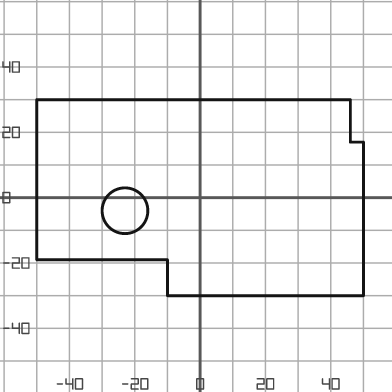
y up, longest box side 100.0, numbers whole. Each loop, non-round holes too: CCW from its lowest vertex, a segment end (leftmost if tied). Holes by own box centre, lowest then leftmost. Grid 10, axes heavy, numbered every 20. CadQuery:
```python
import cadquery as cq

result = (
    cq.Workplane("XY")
    .moveTo(-10.0, -30.0)
    .lineTo(50.0, -30.0)
    .lineTo(50.0, 17.0)
    .lineTo(46.0, 17.0)
    .lineTo(46.0, 30.0)
    .lineTo(-50.0, 30.0)
    .lineTo(-50.0, -19.0)
    .lineTo(-10.0, -19.0)
    .close()
    .moveTo(-23.0, -4.0)
    .circle(7.0)
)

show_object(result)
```